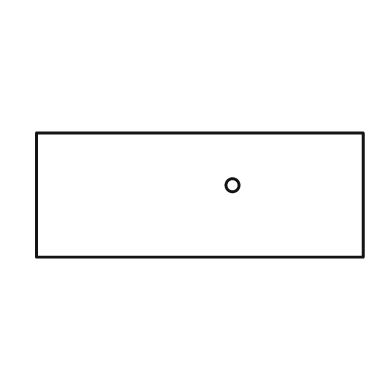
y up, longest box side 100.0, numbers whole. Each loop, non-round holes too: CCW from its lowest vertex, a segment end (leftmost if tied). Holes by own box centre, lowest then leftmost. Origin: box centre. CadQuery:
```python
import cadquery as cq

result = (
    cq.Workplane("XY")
    .moveTo(-50.0, -19.0)
    .lineTo(50.0, -19.0)
    .lineTo(50.0, 19.0)
    .lineTo(-50.0, 19.0)
    .close()
    .moveTo(10.0, 3.0)
    .circle(2.0)
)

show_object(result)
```